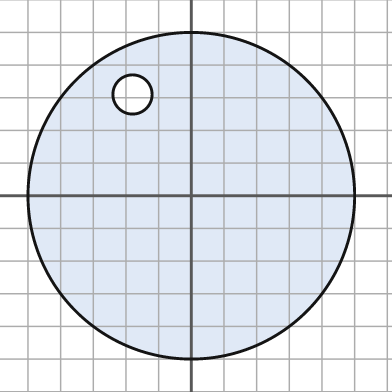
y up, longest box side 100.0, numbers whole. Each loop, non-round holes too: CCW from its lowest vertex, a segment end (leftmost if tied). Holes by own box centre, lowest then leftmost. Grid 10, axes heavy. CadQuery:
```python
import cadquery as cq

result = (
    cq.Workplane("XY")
    .moveTo(0.0, 0.0)
    .circle(50.0)
    .moveTo(-18.0, 31.0)
    .circle(6.0)
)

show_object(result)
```